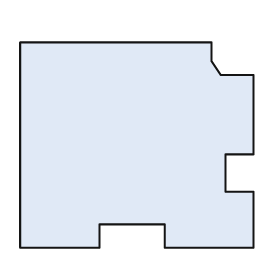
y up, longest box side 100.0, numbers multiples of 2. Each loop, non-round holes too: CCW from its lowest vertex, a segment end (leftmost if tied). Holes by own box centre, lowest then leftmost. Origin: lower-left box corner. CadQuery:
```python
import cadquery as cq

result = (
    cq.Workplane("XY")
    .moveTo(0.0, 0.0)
    .lineTo(34.0, 0.0)
    .lineTo(34.0, 10.0)
    .lineTo(62.0, 10.0)
    .lineTo(62.0, 0.0)
    .lineTo(100.0, 0.0)
    .lineTo(100.0, 24.0)
    .lineTo(88.0, 24.0)
    .lineTo(88.0, 40.0)
    .lineTo(100.0, 40.0)
    .lineTo(100.0, 74.0)
    .lineTo(86.0, 74.0)
    .lineTo(82.0, 80.0)
    .lineTo(82.0, 88.0)
    .lineTo(0.0, 88.0)
    .close()
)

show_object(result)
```